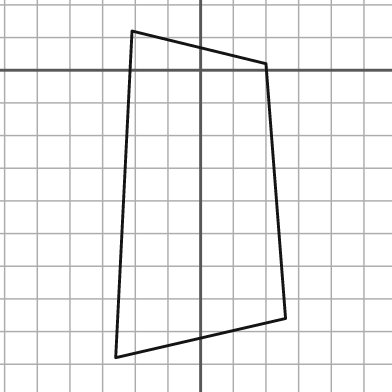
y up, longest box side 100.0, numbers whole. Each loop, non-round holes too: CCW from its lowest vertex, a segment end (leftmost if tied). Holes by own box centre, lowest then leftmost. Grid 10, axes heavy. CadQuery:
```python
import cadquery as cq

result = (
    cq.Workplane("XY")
    .moveTo(-26.0, -88.0)
    .lineTo(26.0, -76.0)
    .lineTo(20.0, 2.0)
    .lineTo(-21.0, 12.0)
    .close()
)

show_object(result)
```